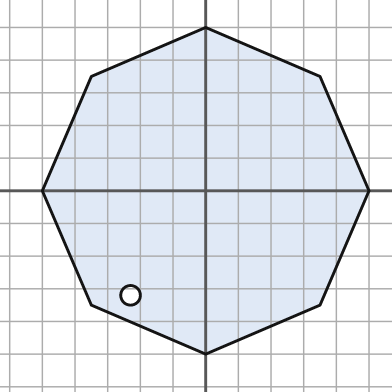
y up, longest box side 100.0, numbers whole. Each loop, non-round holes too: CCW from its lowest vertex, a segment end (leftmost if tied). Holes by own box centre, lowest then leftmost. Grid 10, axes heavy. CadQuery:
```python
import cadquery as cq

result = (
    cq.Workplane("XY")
    .moveTo(0.0, -50.0)
    .lineTo(35.0, -35.0)
    .lineTo(50.0, 0.0)
    .lineTo(35.0, 35.0)
    .lineTo(0.0, 50.0)
    .lineTo(-35.0, 35.0)
    .lineTo(-50.0, 0.0)
    .lineTo(-35.0, -35.0)
    .close()
    .moveTo(-23.0, -32.0)
    .circle(3.0)
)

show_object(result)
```